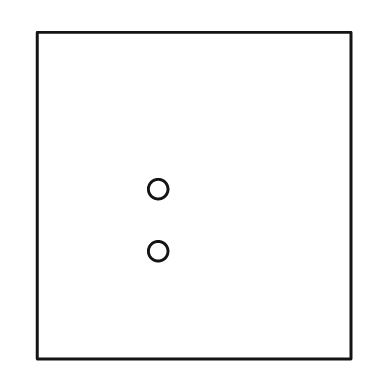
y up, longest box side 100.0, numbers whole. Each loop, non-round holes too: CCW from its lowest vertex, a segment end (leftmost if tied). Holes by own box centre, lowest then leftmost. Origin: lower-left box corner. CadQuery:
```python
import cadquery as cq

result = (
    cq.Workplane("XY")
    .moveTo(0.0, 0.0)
    .lineTo(96.0, 0.0)
    .lineTo(96.0, 100.0)
    .lineTo(0.0, 100.0)
    .close()
    .moveTo(37.0, 33.0)
    .circle(3.0)
    .moveTo(37.0, 52.0)
    .circle(3.0)
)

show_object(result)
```